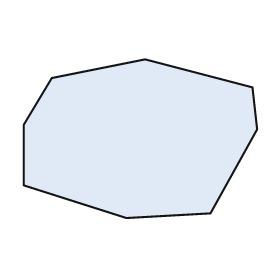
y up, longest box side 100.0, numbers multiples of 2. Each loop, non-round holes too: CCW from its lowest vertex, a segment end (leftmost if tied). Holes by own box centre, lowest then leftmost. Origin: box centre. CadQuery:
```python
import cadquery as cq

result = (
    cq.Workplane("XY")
    .moveTo(-6.0, -34.0)
    .lineTo(30.0, -32.0)
    .lineTo(50.0, 4.0)
    .lineTo(48.0, 22.0)
    .lineTo(2.0, 34.0)
    .lineTo(-38.0, 26.0)
    .lineTo(-50.0, 6.0)
    .lineTo(-50.0, -20.0)
    .close()
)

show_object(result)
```